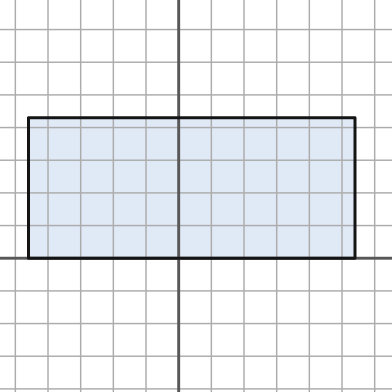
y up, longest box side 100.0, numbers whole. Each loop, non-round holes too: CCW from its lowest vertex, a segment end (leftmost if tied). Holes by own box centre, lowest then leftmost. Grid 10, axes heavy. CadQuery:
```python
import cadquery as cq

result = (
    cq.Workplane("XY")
    .moveTo(-46.0, 0.0)
    .lineTo(54.0, 0.0)
    .lineTo(54.0, 43.0)
    .lineTo(-46.0, 43.0)
    .close()
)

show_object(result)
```